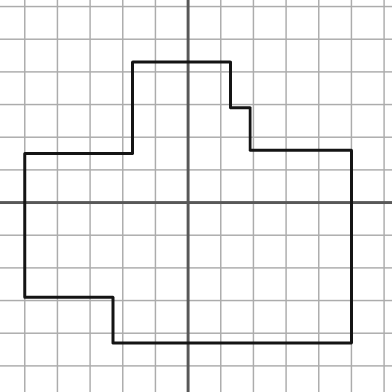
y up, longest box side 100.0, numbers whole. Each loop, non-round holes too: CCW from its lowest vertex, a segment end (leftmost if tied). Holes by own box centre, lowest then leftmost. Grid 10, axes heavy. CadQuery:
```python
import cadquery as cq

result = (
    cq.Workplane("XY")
    .moveTo(-23.0, -43.0)
    .lineTo(50.0, -43.0)
    .lineTo(50.0, 16.0)
    .lineTo(19.0, 16.0)
    .lineTo(19.0, 29.0)
    .lineTo(13.0, 29.0)
    .lineTo(13.0, 43.0)
    .lineTo(-17.0, 43.0)
    .lineTo(-17.0, 15.0)
    .lineTo(-50.0, 15.0)
    .lineTo(-50.0, -29.0)
    .lineTo(-23.0, -29.0)
    .close()
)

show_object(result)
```